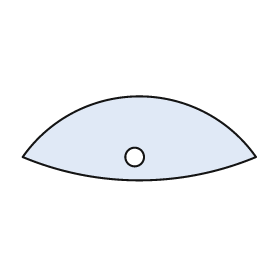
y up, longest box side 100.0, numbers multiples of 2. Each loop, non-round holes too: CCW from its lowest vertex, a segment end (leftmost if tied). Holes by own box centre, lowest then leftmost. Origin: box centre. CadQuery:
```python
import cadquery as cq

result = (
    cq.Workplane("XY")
    .moveTo(-50.0, -8.0)
    .threePointArc((0.0, -18.0), (50.0, -8.0))
    .threePointArc((0.0, 18.0), (-50.0, -8.0))
    .close()
    .moveTo(-2.0, -8.0)
    .circle(4.0)
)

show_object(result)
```